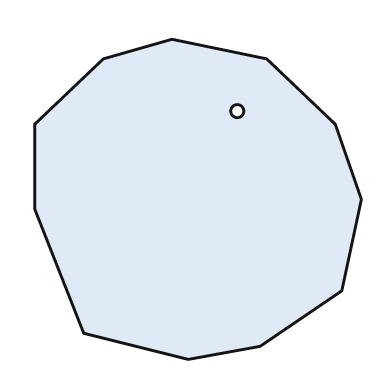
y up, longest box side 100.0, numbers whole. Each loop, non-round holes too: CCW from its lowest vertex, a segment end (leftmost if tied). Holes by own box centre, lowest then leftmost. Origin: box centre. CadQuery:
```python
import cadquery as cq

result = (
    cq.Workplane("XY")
    .moveTo(-3.0, -49.0)
    .lineTo(19.0, -45.0)
    .lineTo(44.0, -28.0)
    .lineTo(50.0, 0.0)
    .lineTo(42.0, 23.0)
    .lineTo(21.0, 43.0)
    .lineTo(-8.0, 49.0)
    .lineTo(-29.0, 43.0)
    .lineTo(-50.0, 23.0)
    .lineTo(-50.0, -3.0)
    .lineTo(-35.0, -41.0)
    .close()
    .moveTo(12.0, 27.0)
    .circle(2.0)
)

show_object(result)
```